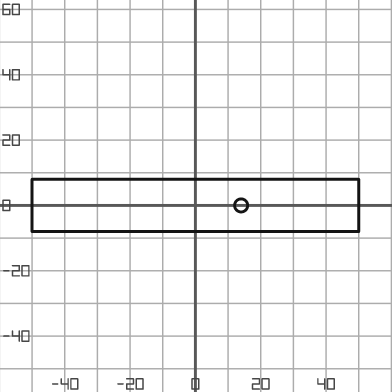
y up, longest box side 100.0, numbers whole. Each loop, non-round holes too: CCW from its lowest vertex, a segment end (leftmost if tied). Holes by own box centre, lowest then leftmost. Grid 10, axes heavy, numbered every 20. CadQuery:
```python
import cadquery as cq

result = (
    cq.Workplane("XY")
    .moveTo(-50.0, -8.0)
    .lineTo(50.0, -8.0)
    .lineTo(50.0, 8.0)
    .lineTo(-50.0, 8.0)
    .close()
    .moveTo(14.0, 0.0)
    .circle(2.0)
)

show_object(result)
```